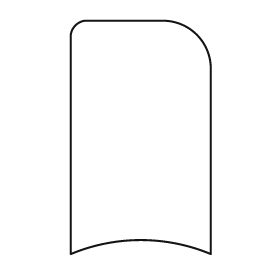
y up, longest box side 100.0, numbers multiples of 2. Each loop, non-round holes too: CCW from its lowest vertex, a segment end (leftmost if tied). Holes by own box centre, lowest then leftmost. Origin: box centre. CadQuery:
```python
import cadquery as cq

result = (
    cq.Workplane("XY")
    .moveTo(-30.0, -50.0)
    .threePointArc((0.0, -44.0), (30.0, -50.0))
    .lineTo(30.0, 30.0)
    .threePointArc((24.0, 44.0), (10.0, 50.0))
    .lineTo(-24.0, 50.0)
    .threePointArc((-28.0, 48.0), (-30.0, 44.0))
    .close()
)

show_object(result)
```